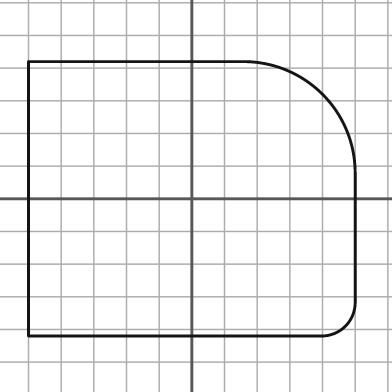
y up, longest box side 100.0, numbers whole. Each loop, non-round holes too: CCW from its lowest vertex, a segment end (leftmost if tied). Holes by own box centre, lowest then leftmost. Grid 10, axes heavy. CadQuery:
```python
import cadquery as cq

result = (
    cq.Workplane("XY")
    .moveTo(-50.0, -42.0)
    .lineTo(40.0, -42.0)
    .threePointArc((47.0, -39.0), (50.0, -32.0))
    .lineTo(50.0, 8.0)
    .threePointArc((40.0, 32.0), (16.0, 42.0))
    .lineTo(-50.0, 42.0)
    .close()
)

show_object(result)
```